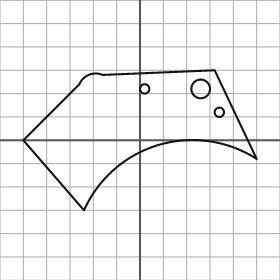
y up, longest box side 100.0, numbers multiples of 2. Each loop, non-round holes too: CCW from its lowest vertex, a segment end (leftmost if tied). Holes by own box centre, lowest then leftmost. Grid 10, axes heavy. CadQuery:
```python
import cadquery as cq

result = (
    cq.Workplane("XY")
    .moveTo(-24.0, -30.0)
    .threePointArc((8.0, -2.0), (50.0, -8.0))
    .lineTo(32.0, 30.0)
    .lineTo(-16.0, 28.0)
    .threePointArc((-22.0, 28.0), (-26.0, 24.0))
    .lineTo(-50.0, 0.0)
    .close()
    .moveTo(34.0, 12.0)
    .circle(2.0)
    .moveTo(2.0, 22.0)
    .circle(2.0)
    .moveTo(26.0, 22.0)
    .circle(4.0)
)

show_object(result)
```